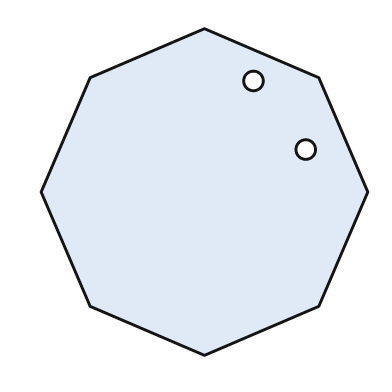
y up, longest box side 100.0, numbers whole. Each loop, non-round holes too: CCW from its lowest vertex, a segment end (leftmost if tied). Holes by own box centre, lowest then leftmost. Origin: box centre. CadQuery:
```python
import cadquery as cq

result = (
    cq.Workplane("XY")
    .moveTo(0.0, -50.0)
    .lineTo(35.0, -35.0)
    .lineTo(50.0, 0.0)
    .lineTo(35.0, 35.0)
    .lineTo(0.0, 50.0)
    .lineTo(-35.0, 35.0)
    .lineTo(-50.0, 0.0)
    .lineTo(-35.0, -35.0)
    .close()
    .moveTo(31.0, 13.0)
    .circle(3.0)
    .moveTo(15.0, 34.0)
    .circle(3.0)
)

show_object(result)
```